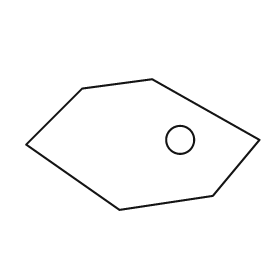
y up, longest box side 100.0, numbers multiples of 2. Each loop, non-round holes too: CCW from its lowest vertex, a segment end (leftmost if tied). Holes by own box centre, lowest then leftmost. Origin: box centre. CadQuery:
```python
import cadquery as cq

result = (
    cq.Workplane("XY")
    .moveTo(-10.0, -28.0)
    .lineTo(30.0, -22.0)
    .lineTo(50.0, 2.0)
    .lineTo(4.0, 28.0)
    .lineTo(-26.0, 24.0)
    .lineTo(-50.0, 0.0)
    .close()
    .moveTo(16.0, 2.0)
    .circle(6.0)
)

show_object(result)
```